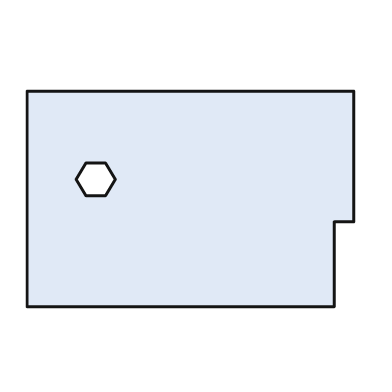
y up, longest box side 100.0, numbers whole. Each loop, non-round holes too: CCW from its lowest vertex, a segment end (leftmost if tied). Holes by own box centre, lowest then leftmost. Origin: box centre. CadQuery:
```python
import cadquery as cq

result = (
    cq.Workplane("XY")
    .moveTo(-50.0, -33.0)
    .lineTo(44.0, -33.0)
    .lineTo(44.0, -7.0)
    .lineTo(50.0, -7.0)
    .lineTo(50.0, 33.0)
    .lineTo(-50.0, 33.0)
    .close()
    .moveTo(-32.0, 1.0)
    .lineTo(-26.0, 1.0)
    .lineTo(-23.0, 6.0)
    .lineTo(-26.0, 11.0)
    .lineTo(-32.0, 11.0)
    .lineTo(-35.0, 6.0)
    .close()
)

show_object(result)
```